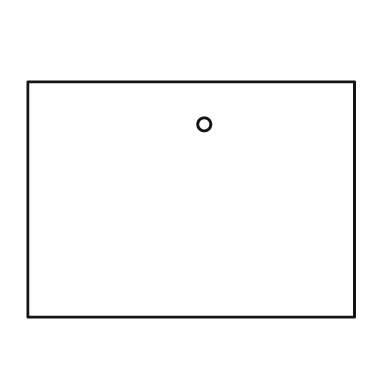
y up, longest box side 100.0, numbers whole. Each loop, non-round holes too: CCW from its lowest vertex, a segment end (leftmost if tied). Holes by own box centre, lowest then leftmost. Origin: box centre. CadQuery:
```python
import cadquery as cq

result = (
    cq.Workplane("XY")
    .moveTo(-50.0, -36.0)
    .lineTo(50.0, -36.0)
    .lineTo(50.0, 36.0)
    .lineTo(-50.0, 36.0)
    .close()
    .moveTo(4.0, 23.0)
    .circle(2.0)
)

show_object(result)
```